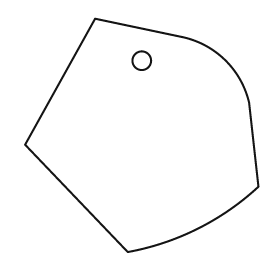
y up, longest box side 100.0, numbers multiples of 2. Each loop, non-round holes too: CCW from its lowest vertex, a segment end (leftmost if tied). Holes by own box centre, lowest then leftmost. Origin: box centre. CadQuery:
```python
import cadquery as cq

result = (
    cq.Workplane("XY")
    .moveTo(-6.0, -50.0)
    .threePointArc((24.0, -40.0), (50.0, -22.0))
    .lineTo(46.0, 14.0)
    .threePointArc((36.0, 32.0), (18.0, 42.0))
    .lineTo(-20.0, 50.0)
    .lineTo(-50.0, -4.0)
    .close()
    .moveTo(0.0, 32.0)
    .circle(4.0)
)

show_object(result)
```